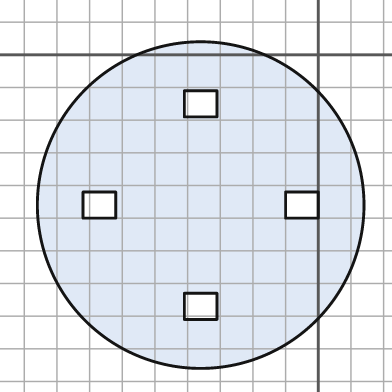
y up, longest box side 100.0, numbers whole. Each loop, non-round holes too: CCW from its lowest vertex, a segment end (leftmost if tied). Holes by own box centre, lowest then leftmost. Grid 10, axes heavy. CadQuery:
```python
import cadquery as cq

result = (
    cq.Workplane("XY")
    .moveTo(-36.0, -46.0)
    .circle(50.0)
    .moveTo(-41.0, -81.0)
    .lineTo(-31.0, -81.0)
    .lineTo(-31.0, -73.0)
    .lineTo(-41.0, -73.0)
    .close()
    .moveTo(-72.0, -50.0)
    .lineTo(-62.0, -50.0)
    .lineTo(-62.0, -42.0)
    .lineTo(-72.0, -42.0)
    .close()
    .moveTo(-10.0, -50.0)
    .lineTo(0.0, -50.0)
    .lineTo(0.0, -42.0)
    .lineTo(-10.0, -42.0)
    .close()
    .moveTo(-41.0, -19.0)
    .lineTo(-31.0, -19.0)
    .lineTo(-31.0, -11.0)
    .lineTo(-41.0, -11.0)
    .close()
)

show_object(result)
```